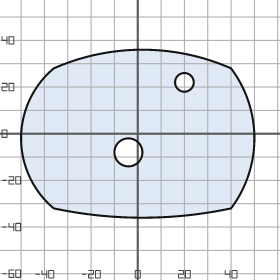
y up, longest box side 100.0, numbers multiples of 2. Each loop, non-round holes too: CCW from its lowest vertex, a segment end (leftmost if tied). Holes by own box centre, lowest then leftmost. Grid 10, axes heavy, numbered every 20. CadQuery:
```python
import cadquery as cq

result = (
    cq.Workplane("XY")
    .moveTo(-36.0, -32.0)
    .threePointArc((2.0, -36.0), (40.0, -32.0))
    .threePointArc((50.0, -2.0), (40.0, 28.0))
    .threePointArc((2.0, 36.0), (-36.0, 28.0))
    .threePointArc((-50.0, -2.0), (-36.0, -32.0))
    .close()
    .moveTo(-4.0, -8.0)
    .circle(6.0)
    .moveTo(20.0, 22.0)
    .circle(4.0)
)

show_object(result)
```